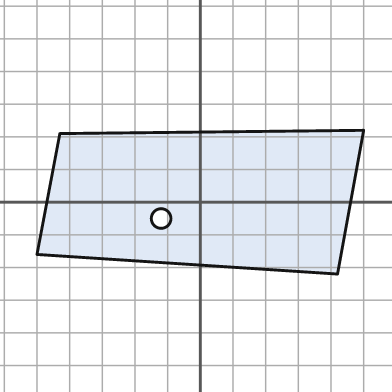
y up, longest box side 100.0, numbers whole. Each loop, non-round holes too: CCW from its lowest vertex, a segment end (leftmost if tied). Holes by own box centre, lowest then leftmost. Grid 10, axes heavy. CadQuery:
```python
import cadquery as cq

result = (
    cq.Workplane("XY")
    .moveTo(42.0, -22.0)
    .lineTo(50.0, 22.0)
    .lineTo(-43.0, 21.0)
    .lineTo(-50.0, -16.0)
    .close()
    .moveTo(-12.0, -5.0)
    .circle(3.0)
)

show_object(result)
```